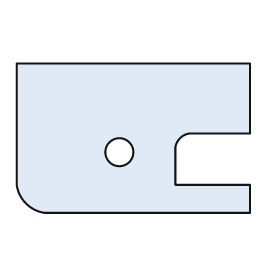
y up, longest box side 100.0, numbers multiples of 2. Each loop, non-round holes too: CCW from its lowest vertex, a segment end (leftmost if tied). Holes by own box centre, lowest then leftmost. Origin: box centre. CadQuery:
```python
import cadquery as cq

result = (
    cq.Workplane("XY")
    .moveTo(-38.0, -32.0)
    .lineTo(50.0, -32.0)
    .lineTo(50.0, -20.0)
    .lineTo(18.0, -20.0)
    .lineTo(18.0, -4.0)
    .threePointArc((20.0, 0.0), (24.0, 2.0))
    .lineTo(50.0, 2.0)
    .lineTo(50.0, 32.0)
    .lineTo(-50.0, 32.0)
    .lineTo(-50.0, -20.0)
    .threePointArc((-46.0, -28.0), (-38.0, -32.0))
    .close()
    .moveTo(-6.0, -6.0)
    .circle(6.0)
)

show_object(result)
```